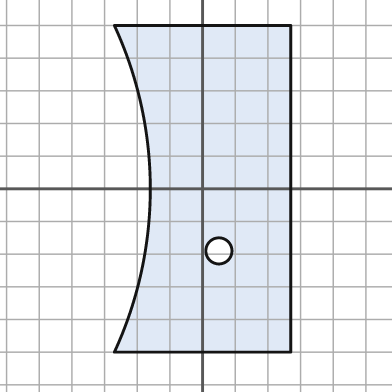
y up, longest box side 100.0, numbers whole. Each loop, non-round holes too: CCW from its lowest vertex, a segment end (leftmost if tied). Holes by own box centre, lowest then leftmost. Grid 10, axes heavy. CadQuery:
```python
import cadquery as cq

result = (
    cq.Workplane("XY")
    .moveTo(-27.0, -50.0)
    .lineTo(27.0, -50.0)
    .lineTo(27.0, 50.0)
    .lineTo(-27.0, 50.0)
    .threePointArc((-16.0, 0.0), (-27.0, -50.0))
    .close()
    .moveTo(5.0, -19.0)
    .circle(4.0)
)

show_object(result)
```